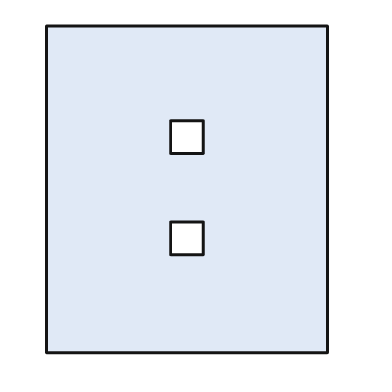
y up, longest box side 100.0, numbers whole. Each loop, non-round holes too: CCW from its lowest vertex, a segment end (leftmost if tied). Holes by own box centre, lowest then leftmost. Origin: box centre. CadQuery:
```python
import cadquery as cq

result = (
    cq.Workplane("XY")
    .moveTo(-43.0, -50.0)
    .lineTo(43.0, -50.0)
    .lineTo(43.0, 50.0)
    .lineTo(-43.0, 50.0)
    .close()
    .moveTo(-5.0, -20.0)
    .lineTo(5.0, -20.0)
    .lineTo(5.0, -10.0)
    .lineTo(-5.0, -10.0)
    .close()
    .moveTo(-5.0, 11.0)
    .lineTo(5.0, 11.0)
    .lineTo(5.0, 21.0)
    .lineTo(-5.0, 21.0)
    .close()
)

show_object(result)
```